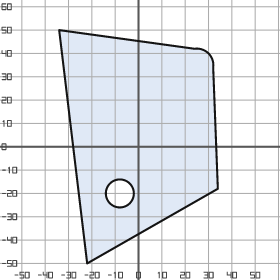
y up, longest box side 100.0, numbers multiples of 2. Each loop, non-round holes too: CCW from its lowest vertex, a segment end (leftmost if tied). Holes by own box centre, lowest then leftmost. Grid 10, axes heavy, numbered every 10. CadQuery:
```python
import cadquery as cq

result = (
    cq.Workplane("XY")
    .moveTo(-22.0, -50.0)
    .lineTo(34.0, -18.0)
    .lineTo(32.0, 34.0)
    .threePointArc((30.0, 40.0), (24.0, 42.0))
    .lineTo(-34.0, 50.0)
    .close()
    .moveTo(-8.0, -20.0)
    .circle(6.0)
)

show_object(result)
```